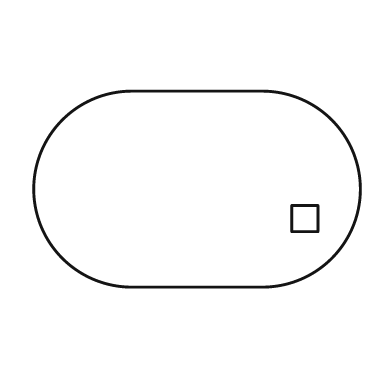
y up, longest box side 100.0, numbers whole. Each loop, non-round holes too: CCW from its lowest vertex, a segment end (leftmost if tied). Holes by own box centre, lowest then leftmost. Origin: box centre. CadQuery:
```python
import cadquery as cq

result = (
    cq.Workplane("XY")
    .moveTo(-20.0, -30.0)
    .lineTo(20.0, -30.0)
    .threePointArc((50.0, 0.0), (20.0, 30.0))
    .lineTo(-20.0, 30.0)
    .threePointArc((-50.0, 0.0), (-20.0, -30.0))
    .close()
    .moveTo(29.0, -13.0)
    .lineTo(37.0, -13.0)
    .lineTo(37.0, -5.0)
    .lineTo(29.0, -5.0)
    .close()
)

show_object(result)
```